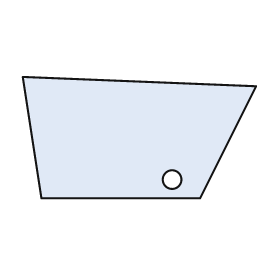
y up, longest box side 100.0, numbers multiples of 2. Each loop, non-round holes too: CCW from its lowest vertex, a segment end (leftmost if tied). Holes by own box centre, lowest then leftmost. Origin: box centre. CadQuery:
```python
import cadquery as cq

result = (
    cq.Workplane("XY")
    .moveTo(-42.0, -26.0)
    .lineTo(26.0, -26.0)
    .lineTo(50.0, 22.0)
    .lineTo(-50.0, 26.0)
    .close()
    .moveTo(14.0, -18.0)
    .circle(4.0)
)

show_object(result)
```